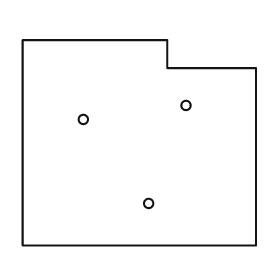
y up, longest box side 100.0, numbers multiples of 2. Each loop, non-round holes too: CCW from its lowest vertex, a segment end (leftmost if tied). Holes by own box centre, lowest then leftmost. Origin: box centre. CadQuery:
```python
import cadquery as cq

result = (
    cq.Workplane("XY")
    .moveTo(-50.0, -44.0)
    .lineTo(50.0, -44.0)
    .lineTo(50.0, 32.0)
    .lineTo(12.0, 32.0)
    .lineTo(12.0, 44.0)
    .lineTo(-50.0, 44.0)
    .close()
    .moveTo(4.0, -26.0)
    .circle(2.0)
    .moveTo(-24.0, 10.0)
    .circle(2.0)
    .moveTo(20.0, 16.0)
    .circle(2.0)
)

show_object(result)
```